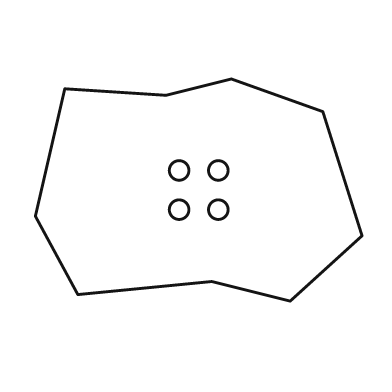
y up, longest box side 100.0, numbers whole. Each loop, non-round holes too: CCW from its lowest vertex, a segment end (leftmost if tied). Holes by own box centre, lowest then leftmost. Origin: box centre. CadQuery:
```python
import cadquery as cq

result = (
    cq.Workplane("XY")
    .moveTo(28.0, -34.0)
    .lineTo(50.0, -14.0)
    .lineTo(38.0, 24.0)
    .lineTo(10.0, 34.0)
    .lineTo(-10.0, 29.0)
    .lineTo(-41.0, 31.0)
    .lineTo(-50.0, -8.0)
    .lineTo(-37.0, -32.0)
    .lineTo(4.0, -28.0)
    .close()
    .moveTo(-6.0, -6.0)
    .circle(3.0)
    .moveTo(6.0, -6.0)
    .circle(3.0)
    .moveTo(-6.0, 6.0)
    .circle(3.0)
    .moveTo(6.0, 6.0)
    .circle(3.0)
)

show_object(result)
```